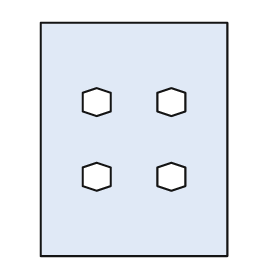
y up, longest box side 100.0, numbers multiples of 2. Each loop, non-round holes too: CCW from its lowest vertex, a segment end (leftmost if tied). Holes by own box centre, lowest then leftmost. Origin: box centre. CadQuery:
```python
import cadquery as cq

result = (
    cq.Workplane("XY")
    .moveTo(-40.0, -50.0)
    .lineTo(40.0, -50.0)
    .lineTo(40.0, 50.0)
    .lineTo(-40.0, 50.0)
    .close()
    .moveTo(-16.0, -22.0)
    .lineTo(-10.0, -20.0)
    .lineTo(-10.0, -12.0)
    .lineTo(-16.0, -10.0)
    .lineTo(-22.0, -12.0)
    .lineTo(-22.0, -20.0)
    .close()
    .moveTo(16.0, -22.0)
    .lineTo(22.0, -20.0)
    .lineTo(22.0, -12.0)
    .lineTo(16.0, -10.0)
    .lineTo(10.0, -12.0)
    .lineTo(10.0, -20.0)
    .close()
    .moveTo(-16.0, 10.0)
    .lineTo(-10.0, 12.0)
    .lineTo(-10.0, 20.0)
    .lineTo(-16.0, 22.0)
    .lineTo(-22.0, 20.0)
    .lineTo(-22.0, 12.0)
    .close()
    .moveTo(16.0, 10.0)
    .lineTo(22.0, 12.0)
    .lineTo(22.0, 20.0)
    .lineTo(16.0, 22.0)
    .lineTo(10.0, 20.0)
    .lineTo(10.0, 12.0)
    .close()
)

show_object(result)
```